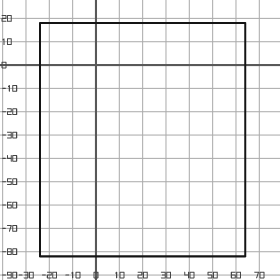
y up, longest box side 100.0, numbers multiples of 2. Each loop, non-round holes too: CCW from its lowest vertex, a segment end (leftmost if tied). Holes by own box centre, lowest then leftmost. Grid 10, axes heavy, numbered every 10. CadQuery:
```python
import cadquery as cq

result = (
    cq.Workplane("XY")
    .moveTo(-24.0, -82.0)
    .lineTo(64.0, -82.0)
    .lineTo(64.0, 18.0)
    .lineTo(-24.0, 18.0)
    .close()
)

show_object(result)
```